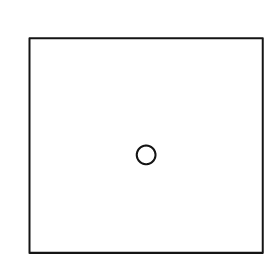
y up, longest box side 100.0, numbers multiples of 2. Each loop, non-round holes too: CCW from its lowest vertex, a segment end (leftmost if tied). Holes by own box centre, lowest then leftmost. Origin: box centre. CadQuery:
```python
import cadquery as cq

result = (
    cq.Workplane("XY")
    .moveTo(-50.0, -46.0)
    .lineTo(50.0, -46.0)
    .lineTo(50.0, 46.0)
    .lineTo(-50.0, 46.0)
    .close()
    .moveTo(0.0, -4.0)
    .circle(4.0)
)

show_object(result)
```